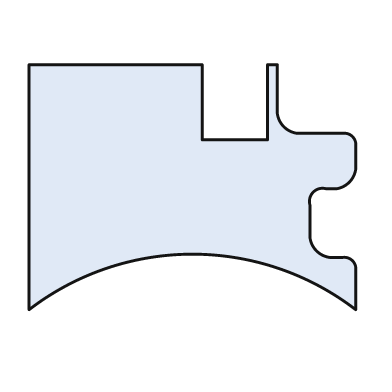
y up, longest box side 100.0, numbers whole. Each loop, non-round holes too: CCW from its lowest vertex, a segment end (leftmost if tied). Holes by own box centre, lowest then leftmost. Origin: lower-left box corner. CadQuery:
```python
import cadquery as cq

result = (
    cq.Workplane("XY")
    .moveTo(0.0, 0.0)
    .threePointArc((50.0, 17.0), (100.0, 0.0))
    .lineTo(100.0, 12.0)
    .threePointArc((99.0, 15.0), (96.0, 16.0))
    .lineTo(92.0, 16.0)
    .threePointArc((88.0, 18.0), (86.0, 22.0))
    .lineTo(86.0, 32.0)
    .threePointArc((87.0, 36.0), (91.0, 37.0))
    .lineTo(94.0, 37.0)
    .threePointArc((98.0, 39.0), (100.0, 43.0))
    .lineTo(100.0, 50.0)
    .threePointArc((99.0, 53.0), (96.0, 54.0))
    .lineTo(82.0, 54.0)
    .threePointArc((78.0, 56.0), (76.0, 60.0))
    .lineTo(76.0, 75.0)
    .lineTo(73.0, 75.0)
    .lineTo(73.0, 52.0)
    .lineTo(53.0, 52.0)
    .lineTo(53.0, 75.0)
    .lineTo(0.0, 75.0)
    .close()
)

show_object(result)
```